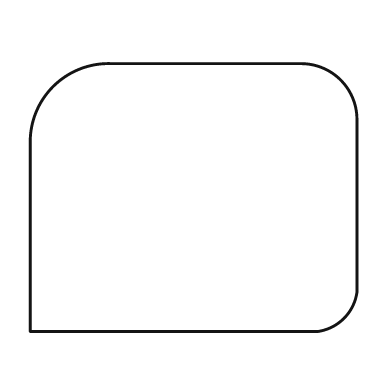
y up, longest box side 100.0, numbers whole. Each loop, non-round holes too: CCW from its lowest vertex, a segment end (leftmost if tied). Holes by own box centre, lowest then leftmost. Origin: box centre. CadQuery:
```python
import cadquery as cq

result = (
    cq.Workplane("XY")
    .moveTo(-50.0, -41.0)
    .lineTo(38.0, -41.0)
    .threePointArc((46.0, -37.0), (50.0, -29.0))
    .lineTo(50.0, 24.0)
    .threePointArc((45.0, 36.0), (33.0, 41.0))
    .lineTo(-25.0, 41.0)
    .threePointArc((-43.0, 34.0), (-50.0, 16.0))
    .close()
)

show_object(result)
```